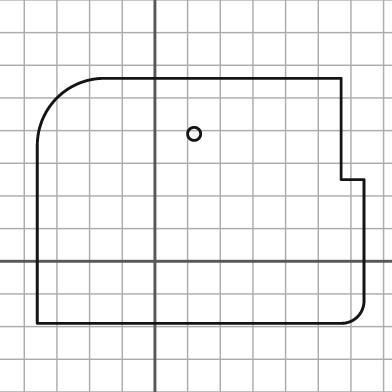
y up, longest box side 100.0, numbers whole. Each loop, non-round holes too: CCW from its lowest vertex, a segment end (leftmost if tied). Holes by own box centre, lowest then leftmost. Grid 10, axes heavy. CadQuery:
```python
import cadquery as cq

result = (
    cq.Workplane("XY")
    .moveTo(-36.0, -19.0)
    .lineTo(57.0, -19.0)
    .threePointArc((62.0, -17.0), (64.0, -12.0))
    .lineTo(64.0, 25.0)
    .lineTo(57.0, 25.0)
    .lineTo(57.0, 56.0)
    .lineTo(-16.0, 56.0)
    .threePointArc((-30.0, 50.0), (-36.0, 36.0))
    .close()
    .moveTo(12.0, 39.0)
    .circle(2.0)
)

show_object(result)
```